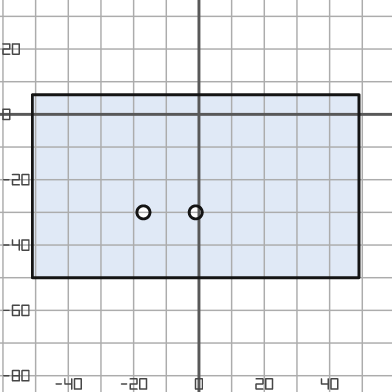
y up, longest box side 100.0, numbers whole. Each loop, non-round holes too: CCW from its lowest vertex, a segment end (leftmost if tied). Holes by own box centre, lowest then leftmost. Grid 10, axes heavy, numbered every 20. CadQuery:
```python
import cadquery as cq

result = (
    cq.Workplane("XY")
    .moveTo(-51.0, -50.0)
    .lineTo(49.0, -50.0)
    .lineTo(49.0, 6.0)
    .lineTo(-51.0, 6.0)
    .close()
    .moveTo(-17.0, -30.0)
    .circle(2.0)
    .moveTo(-1.0, -30.0)
    .circle(2.0)
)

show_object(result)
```